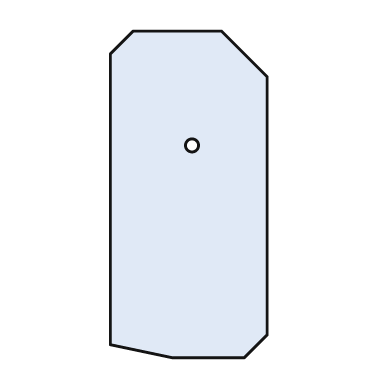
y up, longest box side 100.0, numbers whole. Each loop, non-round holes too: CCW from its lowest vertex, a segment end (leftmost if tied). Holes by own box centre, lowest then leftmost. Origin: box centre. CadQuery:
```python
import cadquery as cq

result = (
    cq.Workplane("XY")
    .moveTo(-5.0, -50.0)
    .lineTo(17.0, -50.0)
    .lineTo(24.0, -43.0)
    .lineTo(24.0, 36.0)
    .lineTo(10.0, 50.0)
    .lineTo(-17.0, 50.0)
    .lineTo(-24.0, 43.0)
    .lineTo(-24.0, -46.0)
    .close()
    .moveTo(1.0, 15.0)
    .circle(2.0)
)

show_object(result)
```